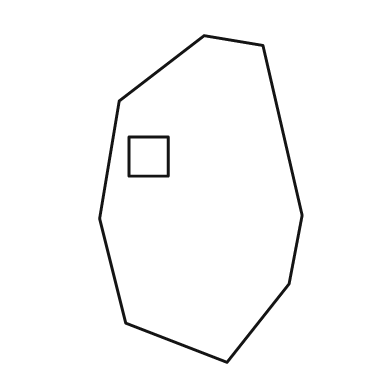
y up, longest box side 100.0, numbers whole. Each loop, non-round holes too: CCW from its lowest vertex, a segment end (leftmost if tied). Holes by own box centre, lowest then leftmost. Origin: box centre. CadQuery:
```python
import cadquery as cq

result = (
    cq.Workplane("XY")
    .moveTo(8.0, -50.0)
    .lineTo(27.0, -26.0)
    .lineTo(31.0, -5.0)
    .lineTo(19.0, 47.0)
    .lineTo(1.0, 50.0)
    .lineTo(-25.0, 30.0)
    .lineTo(-31.0, -6.0)
    .lineTo(-23.0, -38.0)
    .close()
    .moveTo(-22.0, 7.0)
    .lineTo(-10.0, 7.0)
    .lineTo(-10.0, 19.0)
    .lineTo(-22.0, 19.0)
    .close()
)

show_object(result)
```